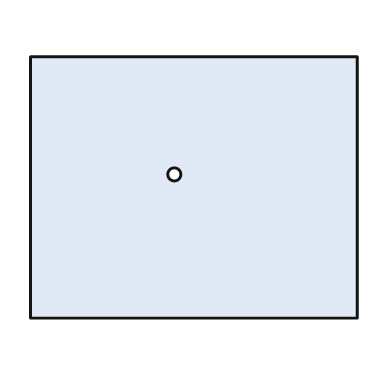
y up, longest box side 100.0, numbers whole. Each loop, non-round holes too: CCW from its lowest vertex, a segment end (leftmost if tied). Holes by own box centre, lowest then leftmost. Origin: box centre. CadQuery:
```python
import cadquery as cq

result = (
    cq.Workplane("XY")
    .moveTo(-50.0, -40.0)
    .lineTo(50.0, -40.0)
    .lineTo(50.0, 40.0)
    .lineTo(-50.0, 40.0)
    .close()
    .moveTo(-6.0, 4.0)
    .circle(2.0)
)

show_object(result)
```